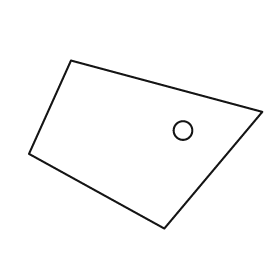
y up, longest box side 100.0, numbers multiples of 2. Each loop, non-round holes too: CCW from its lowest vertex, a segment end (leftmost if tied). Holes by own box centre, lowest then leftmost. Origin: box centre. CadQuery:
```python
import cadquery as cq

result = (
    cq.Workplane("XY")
    .moveTo(8.0, -36.0)
    .lineTo(50.0, 14.0)
    .lineTo(-32.0, 36.0)
    .lineTo(-50.0, -4.0)
    .close()
    .moveTo(16.0, 6.0)
    .circle(4.0)
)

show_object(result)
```